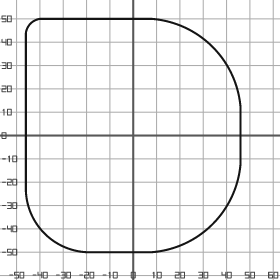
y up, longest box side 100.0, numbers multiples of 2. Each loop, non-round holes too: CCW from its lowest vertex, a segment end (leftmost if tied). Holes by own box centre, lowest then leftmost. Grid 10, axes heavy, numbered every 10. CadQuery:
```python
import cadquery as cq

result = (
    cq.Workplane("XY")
    .moveTo(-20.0, -50.0)
    .lineTo(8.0, -50.0)
    .threePointArc((34.0, -38.0), (46.0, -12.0))
    .lineTo(46.0, 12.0)
    .threePointArc((34.0, 38.0), (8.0, 50.0))
    .lineTo(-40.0, 50.0)
    .threePointArc((-44.0, 48.0), (-46.0, 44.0))
    .lineTo(-46.0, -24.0)
    .threePointArc((-38.0, -42.0), (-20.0, -50.0))
    .close()
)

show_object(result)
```